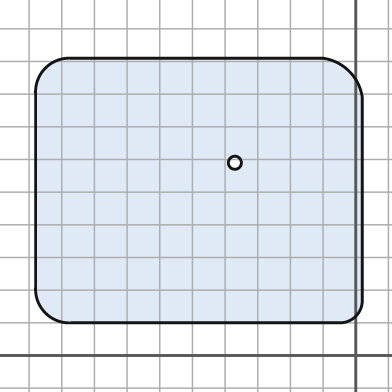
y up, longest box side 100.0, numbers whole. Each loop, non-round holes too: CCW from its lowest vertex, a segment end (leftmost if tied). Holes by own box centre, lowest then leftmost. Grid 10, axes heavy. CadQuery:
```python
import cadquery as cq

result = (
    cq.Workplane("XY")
    .moveTo(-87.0, 10.0)
    .lineTo(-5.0, 10.0)
    .threePointArc((0.0, 12.0), (2.0, 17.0))
    .lineTo(2.0, 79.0)
    .threePointArc((-2.0, 87.0), (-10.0, 91.0))
    .lineTo(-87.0, 91.0)
    .threePointArc((-95.0, 88.0), (-98.0, 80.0))
    .lineTo(-98.0, 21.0)
    .threePointArc((-95.0, 13.0), (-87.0, 10.0))
    .close()
    .moveTo(-37.0, 59.0)
    .circle(2.0)
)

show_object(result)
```